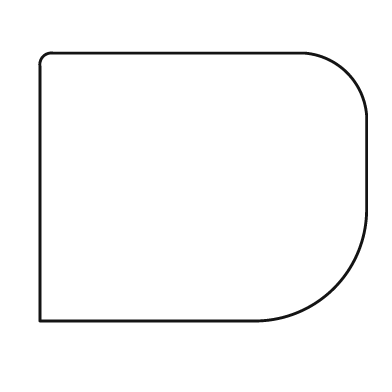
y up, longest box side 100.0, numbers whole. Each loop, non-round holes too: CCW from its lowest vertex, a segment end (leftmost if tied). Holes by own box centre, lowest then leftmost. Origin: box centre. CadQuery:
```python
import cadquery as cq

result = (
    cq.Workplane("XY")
    .moveTo(-50.0, -41.0)
    .lineTo(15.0, -41.0)
    .threePointArc((40.0, -31.0), (50.0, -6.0))
    .lineTo(50.0, 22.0)
    .threePointArc((44.0, 35.0), (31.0, 41.0))
    .lineTo(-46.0, 41.0)
    .threePointArc((-49.0, 40.0), (-50.0, 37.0))
    .close()
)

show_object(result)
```